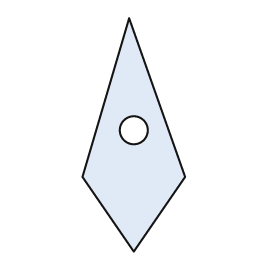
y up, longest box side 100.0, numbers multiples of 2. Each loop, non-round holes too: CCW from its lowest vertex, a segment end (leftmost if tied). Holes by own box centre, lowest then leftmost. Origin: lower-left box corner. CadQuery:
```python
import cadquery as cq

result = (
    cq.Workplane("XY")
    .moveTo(22.0, 0.0)
    .lineTo(44.0, 32.0)
    .lineTo(20.0, 100.0)
    .lineTo(0.0, 32.0)
    .close()
    .moveTo(22.0, 52.0)
    .circle(6.0)
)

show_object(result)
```